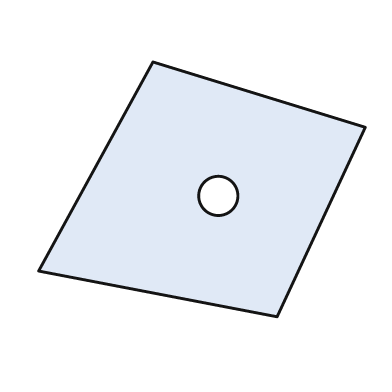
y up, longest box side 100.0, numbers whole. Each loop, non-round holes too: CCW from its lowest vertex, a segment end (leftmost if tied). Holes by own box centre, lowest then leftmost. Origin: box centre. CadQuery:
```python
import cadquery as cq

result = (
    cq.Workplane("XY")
    .moveTo(23.0, -39.0)
    .lineTo(50.0, 19.0)
    .lineTo(-15.0, 39.0)
    .lineTo(-50.0, -25.0)
    .close()
    .moveTo(5.0, -2.0)
    .circle(6.0)
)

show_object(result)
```